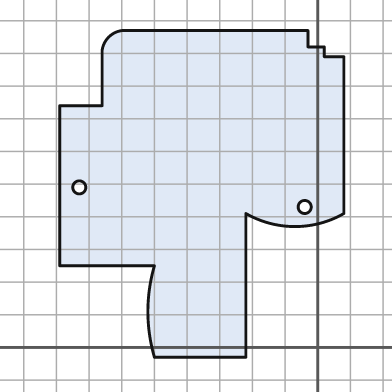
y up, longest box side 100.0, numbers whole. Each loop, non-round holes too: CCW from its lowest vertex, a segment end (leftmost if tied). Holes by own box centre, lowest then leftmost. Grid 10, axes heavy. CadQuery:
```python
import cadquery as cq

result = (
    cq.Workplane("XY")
    .moveTo(-50.0, -3.0)
    .lineTo(-22.0, -3.0)
    .lineTo(-22.0, 41.0)
    .threePointArc((-7.0, 37.0), (8.0, 41.0))
    .lineTo(8.0, 89.0)
    .lineTo(2.0, 89.0)
    .lineTo(2.0, 92.0)
    .lineTo(-3.0, 92.0)
    .lineTo(-3.0, 97.0)
    .lineTo(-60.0, 97.0)
    .threePointArc((-64.0, 95.0), (-66.0, 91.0))
    .lineTo(-66.0, 74.0)
    .lineTo(-79.0, 74.0)
    .lineTo(-79.0, 25.0)
    .lineTo(-50.0, 25.0)
    .threePointArc((-52.0, 11.0), (-50.0, -3.0))
    .close()
    .moveTo(-4.0, 43.0)
    .circle(2.0)
    .moveTo(-73.0, 49.0)
    .circle(2.0)
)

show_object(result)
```